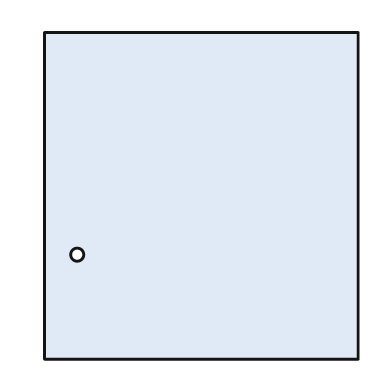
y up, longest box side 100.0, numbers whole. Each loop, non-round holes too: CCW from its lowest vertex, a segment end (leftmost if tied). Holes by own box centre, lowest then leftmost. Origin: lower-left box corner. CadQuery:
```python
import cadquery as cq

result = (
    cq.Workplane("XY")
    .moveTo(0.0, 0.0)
    .lineTo(96.0, 0.0)
    .lineTo(96.0, 100.0)
    .lineTo(0.0, 100.0)
    .close()
    .moveTo(10.0, 32.0)
    .circle(2.0)
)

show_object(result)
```